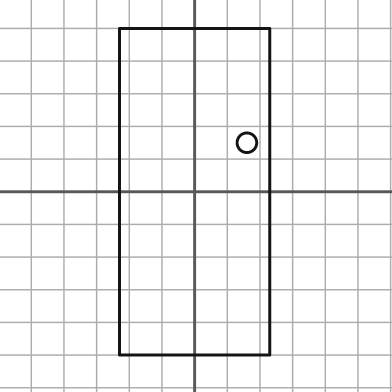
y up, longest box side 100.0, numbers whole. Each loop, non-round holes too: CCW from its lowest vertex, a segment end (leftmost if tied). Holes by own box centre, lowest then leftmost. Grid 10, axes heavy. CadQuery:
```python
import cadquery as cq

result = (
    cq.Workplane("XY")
    .moveTo(-23.0, -50.0)
    .lineTo(23.0, -50.0)
    .lineTo(23.0, 50.0)
    .lineTo(-23.0, 50.0)
    .close()
    .moveTo(16.0, 15.0)
    .circle(3.0)
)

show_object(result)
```